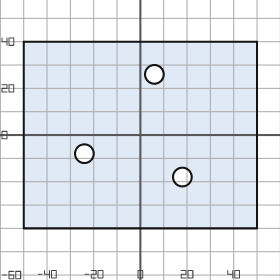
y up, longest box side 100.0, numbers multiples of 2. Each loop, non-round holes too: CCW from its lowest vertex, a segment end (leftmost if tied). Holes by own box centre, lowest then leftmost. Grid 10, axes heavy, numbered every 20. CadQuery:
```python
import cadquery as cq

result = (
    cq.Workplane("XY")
    .moveTo(-50.0, -40.0)
    .lineTo(50.0, -40.0)
    .lineTo(50.0, 40.0)
    .lineTo(-50.0, 40.0)
    .close()
    .moveTo(18.0, -18.0)
    .circle(4.0)
    .moveTo(-24.0, -8.0)
    .circle(4.0)
    .moveTo(6.0, 26.0)
    .circle(4.0)
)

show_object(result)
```